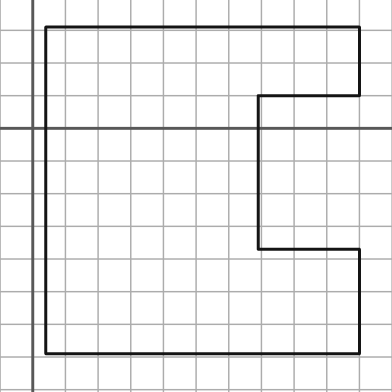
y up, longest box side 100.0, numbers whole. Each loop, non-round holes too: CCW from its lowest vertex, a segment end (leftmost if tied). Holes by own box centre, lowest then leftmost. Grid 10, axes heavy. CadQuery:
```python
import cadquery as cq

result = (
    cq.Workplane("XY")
    .moveTo(4.0, -69.0)
    .lineTo(100.0, -69.0)
    .lineTo(100.0, -37.0)
    .lineTo(69.0, -37.0)
    .lineTo(69.0, 10.0)
    .lineTo(100.0, 10.0)
    .lineTo(100.0, 31.0)
    .lineTo(4.0, 31.0)
    .close()
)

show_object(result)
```